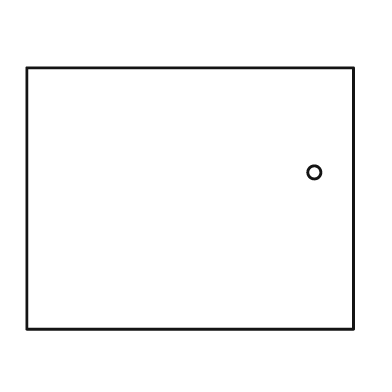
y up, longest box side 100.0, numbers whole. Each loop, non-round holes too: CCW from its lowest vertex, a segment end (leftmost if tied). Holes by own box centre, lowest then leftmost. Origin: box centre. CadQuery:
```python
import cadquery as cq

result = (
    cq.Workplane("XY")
    .moveTo(-50.0, -40.0)
    .lineTo(50.0, -40.0)
    .lineTo(50.0, 40.0)
    .lineTo(-50.0, 40.0)
    .close()
    .moveTo(38.0, 8.0)
    .circle(2.0)
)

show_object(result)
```